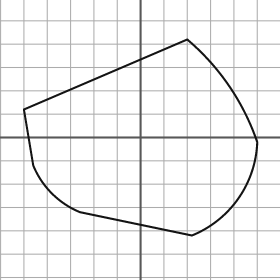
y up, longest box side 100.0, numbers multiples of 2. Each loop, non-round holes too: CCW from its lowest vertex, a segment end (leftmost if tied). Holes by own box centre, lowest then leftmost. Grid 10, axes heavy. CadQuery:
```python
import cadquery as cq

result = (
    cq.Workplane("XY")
    .moveTo(22.0, -42.0)
    .threePointArc((42.0, -26.0), (50.0, -2.0))
    .threePointArc((38.0, 22.0), (20.0, 42.0))
    .lineTo(-50.0, 12.0)
    .lineTo(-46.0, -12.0)
    .threePointArc((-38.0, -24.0), (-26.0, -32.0))
    .close()
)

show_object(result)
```